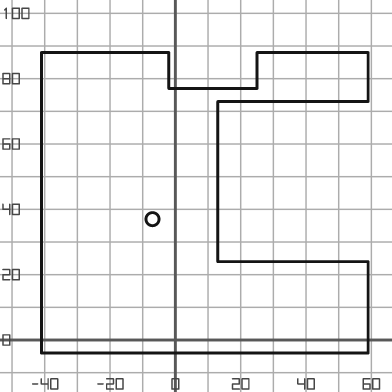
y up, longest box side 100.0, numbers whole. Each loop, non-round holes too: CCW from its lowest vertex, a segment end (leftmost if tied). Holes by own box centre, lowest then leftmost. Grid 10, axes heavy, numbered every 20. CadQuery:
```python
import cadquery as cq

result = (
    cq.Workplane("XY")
    .moveTo(-41.0, -4.0)
    .lineTo(59.0, -4.0)
    .lineTo(59.0, 24.0)
    .lineTo(13.0, 24.0)
    .lineTo(13.0, 73.0)
    .lineTo(59.0, 73.0)
    .lineTo(59.0, 88.0)
    .lineTo(25.0, 88.0)
    .lineTo(25.0, 77.0)
    .lineTo(-2.0, 77.0)
    .lineTo(-2.0, 88.0)
    .lineTo(-41.0, 88.0)
    .close()
    .moveTo(-7.0, 37.0)
    .circle(2.0)
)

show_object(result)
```